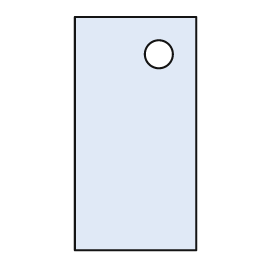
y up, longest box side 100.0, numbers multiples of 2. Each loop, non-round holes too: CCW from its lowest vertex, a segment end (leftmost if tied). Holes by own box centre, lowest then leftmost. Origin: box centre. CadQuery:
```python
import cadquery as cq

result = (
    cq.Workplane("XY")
    .moveTo(-26.0, -50.0)
    .lineTo(26.0, -50.0)
    .lineTo(26.0, 50.0)
    .lineTo(-26.0, 50.0)
    .close()
    .moveTo(10.0, 34.0)
    .circle(6.0)
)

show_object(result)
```